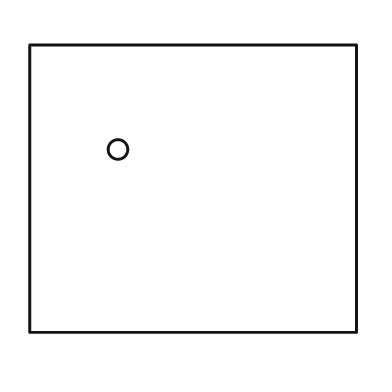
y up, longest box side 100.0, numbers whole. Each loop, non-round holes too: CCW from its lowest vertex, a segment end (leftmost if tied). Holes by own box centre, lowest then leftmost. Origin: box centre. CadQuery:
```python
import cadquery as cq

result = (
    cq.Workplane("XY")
    .moveTo(-50.0, -44.0)
    .lineTo(50.0, -44.0)
    .lineTo(50.0, 44.0)
    .lineTo(-50.0, 44.0)
    .close()
    .moveTo(-23.0, 12.0)
    .circle(3.0)
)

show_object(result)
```